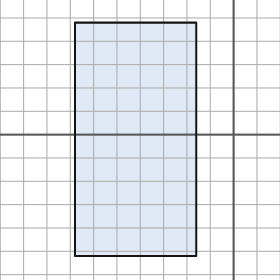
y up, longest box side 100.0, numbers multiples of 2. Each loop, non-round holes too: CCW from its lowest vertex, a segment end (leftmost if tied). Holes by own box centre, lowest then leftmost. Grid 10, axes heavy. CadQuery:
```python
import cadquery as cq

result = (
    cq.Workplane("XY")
    .moveTo(-68.0, -52.0)
    .lineTo(-16.0, -52.0)
    .lineTo(-16.0, 48.0)
    .lineTo(-68.0, 48.0)
    .close()
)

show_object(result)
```